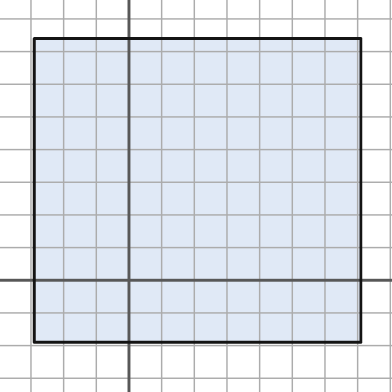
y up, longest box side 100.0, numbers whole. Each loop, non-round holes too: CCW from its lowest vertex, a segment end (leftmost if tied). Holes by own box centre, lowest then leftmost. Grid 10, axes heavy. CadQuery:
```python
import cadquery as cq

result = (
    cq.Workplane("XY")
    .moveTo(-29.0, -19.0)
    .lineTo(71.0, -19.0)
    .lineTo(71.0, 74.0)
    .lineTo(-29.0, 74.0)
    .close()
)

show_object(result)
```